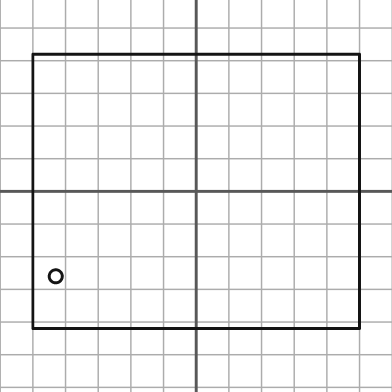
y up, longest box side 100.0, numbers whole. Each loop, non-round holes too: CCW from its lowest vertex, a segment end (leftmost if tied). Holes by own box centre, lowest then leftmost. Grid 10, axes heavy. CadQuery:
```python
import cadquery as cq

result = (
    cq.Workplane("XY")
    .moveTo(-50.0, -42.0)
    .lineTo(50.0, -42.0)
    .lineTo(50.0, 42.0)
    .lineTo(-50.0, 42.0)
    .close()
    .moveTo(-43.0, -26.0)
    .circle(2.0)
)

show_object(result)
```